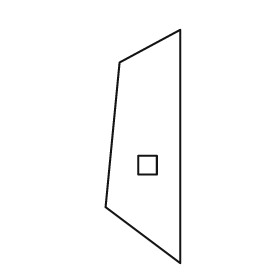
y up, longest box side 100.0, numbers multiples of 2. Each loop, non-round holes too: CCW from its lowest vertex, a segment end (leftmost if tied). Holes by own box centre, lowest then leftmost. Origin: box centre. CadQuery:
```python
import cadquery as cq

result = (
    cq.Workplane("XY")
    .moveTo(16.0, -50.0)
    .lineTo(16.0, 50.0)
    .lineTo(-10.0, 36.0)
    .lineTo(-16.0, -26.0)
    .close()
    .moveTo(-2.0, -12.0)
    .lineTo(6.0, -12.0)
    .lineTo(6.0, -4.0)
    .lineTo(-2.0, -4.0)
    .close()
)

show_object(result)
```